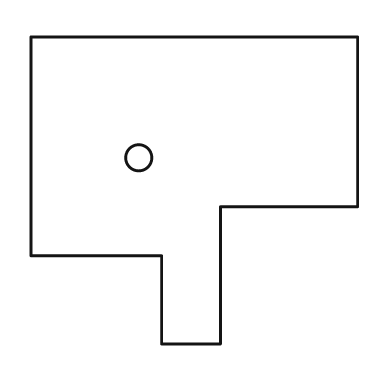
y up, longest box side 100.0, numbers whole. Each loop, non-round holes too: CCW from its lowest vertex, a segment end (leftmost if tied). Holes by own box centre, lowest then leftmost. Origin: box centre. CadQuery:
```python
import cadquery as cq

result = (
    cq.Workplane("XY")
    .moveTo(-10.0, -47.0)
    .lineTo(8.0, -47.0)
    .lineTo(8.0, -5.0)
    .lineTo(50.0, -5.0)
    .lineTo(50.0, 47.0)
    .lineTo(-50.0, 47.0)
    .lineTo(-50.0, -20.0)
    .lineTo(-10.0, -20.0)
    .close()
    .moveTo(-17.0, 10.0)
    .circle(4.0)
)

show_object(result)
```